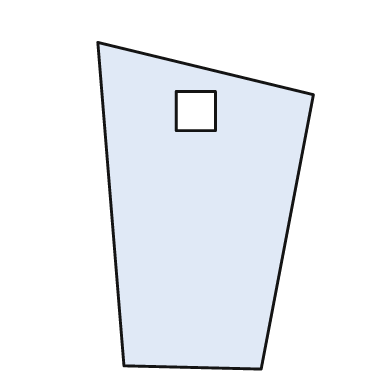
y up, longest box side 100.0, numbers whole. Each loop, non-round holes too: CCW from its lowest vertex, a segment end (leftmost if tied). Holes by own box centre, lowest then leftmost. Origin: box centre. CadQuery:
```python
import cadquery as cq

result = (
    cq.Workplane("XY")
    .moveTo(17.0, -50.0)
    .lineTo(33.0, 34.0)
    .lineTo(-33.0, 50.0)
    .lineTo(-25.0, -49.0)
    .close()
    .moveTo(-9.0, 23.0)
    .lineTo(3.0, 23.0)
    .lineTo(3.0, 35.0)
    .lineTo(-9.0, 35.0)
    .close()
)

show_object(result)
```